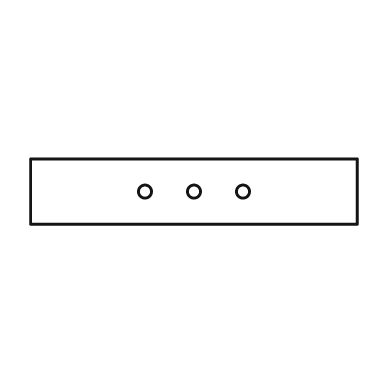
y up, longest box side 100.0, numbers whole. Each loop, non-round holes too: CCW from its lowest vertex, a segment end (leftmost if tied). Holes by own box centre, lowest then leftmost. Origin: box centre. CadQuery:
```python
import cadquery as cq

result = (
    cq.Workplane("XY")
    .moveTo(-50.0, -10.0)
    .lineTo(50.0, -10.0)
    .lineTo(50.0, 10.0)
    .lineTo(-50.0, 10.0)
    .close()
    .moveTo(-15.0, 0.0)
    .circle(2.0)
    .moveTo(0.0, 0.0)
    .circle(2.0)
    .moveTo(15.0, 0.0)
    .circle(2.0)
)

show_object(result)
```